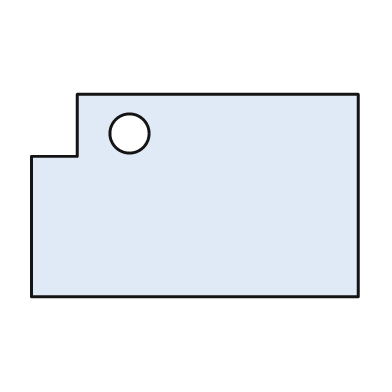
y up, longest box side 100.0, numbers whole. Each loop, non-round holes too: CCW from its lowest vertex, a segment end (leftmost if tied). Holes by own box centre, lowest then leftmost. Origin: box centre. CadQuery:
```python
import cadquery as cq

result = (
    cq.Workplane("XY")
    .moveTo(-50.0, -31.0)
    .lineTo(50.0, -31.0)
    .lineTo(50.0, 31.0)
    .lineTo(-36.0, 31.0)
    .lineTo(-36.0, 12.0)
    .lineTo(-50.0, 12.0)
    .close()
    .moveTo(-20.0, 19.0)
    .circle(6.0)
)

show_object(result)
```